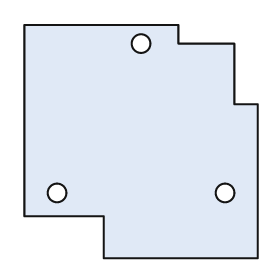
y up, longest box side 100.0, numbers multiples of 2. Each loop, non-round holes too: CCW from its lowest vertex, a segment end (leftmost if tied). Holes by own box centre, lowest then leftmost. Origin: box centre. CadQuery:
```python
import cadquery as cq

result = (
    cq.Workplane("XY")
    .moveTo(-16.0, -50.0)
    .lineTo(50.0, -50.0)
    .lineTo(50.0, 16.0)
    .lineTo(40.0, 16.0)
    .lineTo(40.0, 42.0)
    .lineTo(16.0, 42.0)
    .lineTo(16.0, 50.0)
    .lineTo(-50.0, 50.0)
    .lineTo(-50.0, -32.0)
    .lineTo(-16.0, -32.0)
    .close()
    .moveTo(-36.0, -22.0)
    .circle(4.0)
    .moveTo(36.0, -22.0)
    .circle(4.0)
    .moveTo(0.0, 42.0)
    .circle(4.0)
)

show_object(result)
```